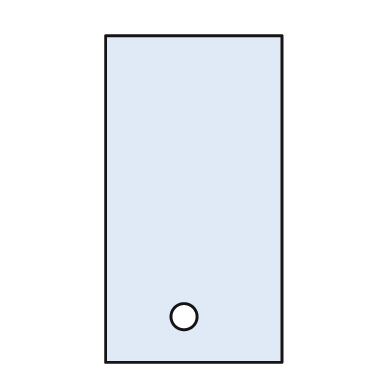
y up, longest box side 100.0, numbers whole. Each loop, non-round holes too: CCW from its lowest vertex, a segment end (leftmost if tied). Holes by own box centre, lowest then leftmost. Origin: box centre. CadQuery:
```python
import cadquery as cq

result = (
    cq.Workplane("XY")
    .moveTo(-27.0, -50.0)
    .lineTo(27.0, -50.0)
    .lineTo(27.0, 50.0)
    .lineTo(-27.0, 50.0)
    .close()
    .moveTo(-3.0, -36.0)
    .circle(4.0)
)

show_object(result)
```